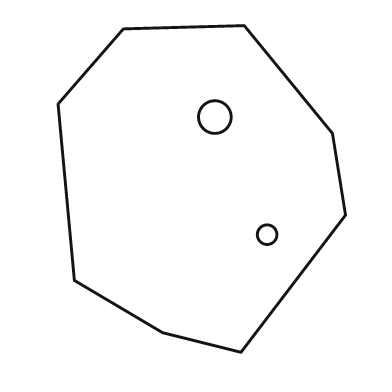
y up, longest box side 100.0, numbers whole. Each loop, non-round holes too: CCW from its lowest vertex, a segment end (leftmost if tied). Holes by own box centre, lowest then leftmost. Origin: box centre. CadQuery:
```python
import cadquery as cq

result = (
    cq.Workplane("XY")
    .moveTo(12.0, -50.0)
    .lineTo(44.0, -8.0)
    .lineTo(40.0, 17.0)
    .lineTo(13.0, 50.0)
    .lineTo(-24.0, 49.0)
    .lineTo(-44.0, 26.0)
    .lineTo(-39.0, -28.0)
    .lineTo(-12.0, -44.0)
    .close()
    .moveTo(20.0, -14.0)
    .circle(3.0)
    .moveTo(4.0, 22.0)
    .circle(5.0)
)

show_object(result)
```